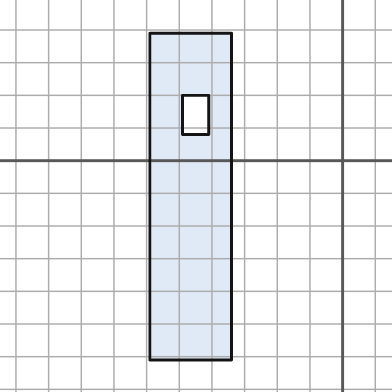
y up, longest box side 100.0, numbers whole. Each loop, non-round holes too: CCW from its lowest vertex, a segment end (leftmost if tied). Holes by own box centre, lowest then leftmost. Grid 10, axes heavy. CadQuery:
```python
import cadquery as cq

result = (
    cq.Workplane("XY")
    .moveTo(-59.0, -61.0)
    .lineTo(-34.0, -61.0)
    .lineTo(-34.0, 39.0)
    .lineTo(-59.0, 39.0)
    .close()
    .moveTo(-49.0, 8.0)
    .lineTo(-41.0, 8.0)
    .lineTo(-41.0, 20.0)
    .lineTo(-49.0, 20.0)
    .close()
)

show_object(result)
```